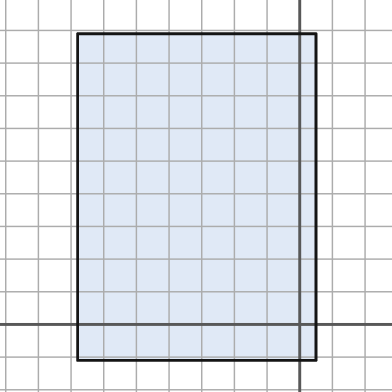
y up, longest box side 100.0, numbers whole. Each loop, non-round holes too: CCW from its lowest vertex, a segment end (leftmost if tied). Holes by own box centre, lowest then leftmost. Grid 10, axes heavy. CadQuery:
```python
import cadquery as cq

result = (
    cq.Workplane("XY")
    .moveTo(-68.0, -11.0)
    .lineTo(5.0, -11.0)
    .lineTo(5.0, 89.0)
    .lineTo(-68.0, 89.0)
    .close()
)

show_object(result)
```